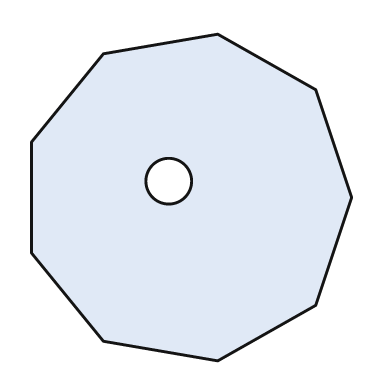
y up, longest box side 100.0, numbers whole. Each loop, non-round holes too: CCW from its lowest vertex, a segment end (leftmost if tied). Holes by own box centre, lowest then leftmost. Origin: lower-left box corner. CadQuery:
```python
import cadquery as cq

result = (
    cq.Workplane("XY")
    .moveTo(57.0, 0.0)
    .lineTo(87.0, 17.0)
    .lineTo(98.0, 50.0)
    .lineTo(87.0, 83.0)
    .lineTo(57.0, 100.0)
    .lineTo(22.0, 94.0)
    .lineTo(0.0, 67.0)
    .lineTo(0.0, 33.0)
    .lineTo(22.0, 6.0)
    .close()
    .moveTo(42.0, 55.0)
    .circle(7.0)
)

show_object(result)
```